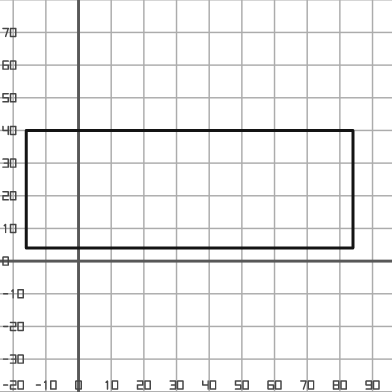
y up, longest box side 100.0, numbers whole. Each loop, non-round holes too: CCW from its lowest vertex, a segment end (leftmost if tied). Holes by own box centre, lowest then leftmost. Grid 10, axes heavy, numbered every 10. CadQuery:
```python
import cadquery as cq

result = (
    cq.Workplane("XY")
    .moveTo(-16.0, 4.0)
    .lineTo(84.0, 4.0)
    .lineTo(84.0, 40.0)
    .lineTo(-16.0, 40.0)
    .close()
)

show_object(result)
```